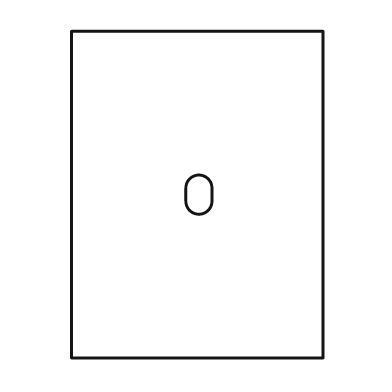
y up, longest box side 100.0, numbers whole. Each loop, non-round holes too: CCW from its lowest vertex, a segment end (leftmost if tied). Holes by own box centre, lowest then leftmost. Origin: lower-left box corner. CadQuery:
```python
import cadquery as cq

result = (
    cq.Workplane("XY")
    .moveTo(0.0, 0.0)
    .lineTo(77.0, 0.0)
    .lineTo(77.0, 100.0)
    .lineTo(0.0, 100.0)
    .close()
    .moveTo(35.0, 48.0)
    .threePointArc((39.0, 44.0), (43.0, 48.0))
    .lineTo(43.0, 52.0)
    .threePointArc((39.0, 56.0), (35.0, 52.0))
    .close()
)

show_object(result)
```